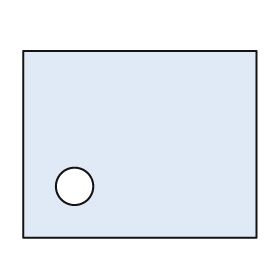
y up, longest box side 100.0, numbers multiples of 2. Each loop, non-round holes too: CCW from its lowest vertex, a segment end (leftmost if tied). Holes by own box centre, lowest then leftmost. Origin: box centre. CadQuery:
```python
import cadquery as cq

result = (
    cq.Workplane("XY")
    .moveTo(-50.0, -40.0)
    .lineTo(50.0, -40.0)
    .lineTo(50.0, 40.0)
    .lineTo(-50.0, 40.0)
    .close()
    .moveTo(-28.0, -18.0)
    .circle(8.0)
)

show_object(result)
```